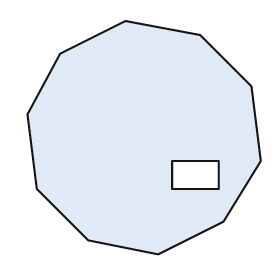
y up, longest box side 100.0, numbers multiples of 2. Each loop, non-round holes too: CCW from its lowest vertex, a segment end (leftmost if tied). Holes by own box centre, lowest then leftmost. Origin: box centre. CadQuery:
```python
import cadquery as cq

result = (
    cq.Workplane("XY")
    .moveTo(6.0, -50.0)
    .lineTo(34.0, -36.0)
    .lineTo(50.0, -10.0)
    .lineTo(46.0, 22.0)
    .lineTo(24.0, 44.0)
    .lineTo(-8.0, 50.0)
    .lineTo(-36.0, 36.0)
    .lineTo(-50.0, 10.0)
    .lineTo(-46.0, -22.0)
    .lineTo(-24.0, -44.0)
    .close()
    .moveTo(12.0, -22.0)
    .lineTo(32.0, -22.0)
    .lineTo(32.0, -10.0)
    .lineTo(12.0, -10.0)
    .close()
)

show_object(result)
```